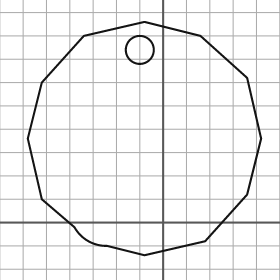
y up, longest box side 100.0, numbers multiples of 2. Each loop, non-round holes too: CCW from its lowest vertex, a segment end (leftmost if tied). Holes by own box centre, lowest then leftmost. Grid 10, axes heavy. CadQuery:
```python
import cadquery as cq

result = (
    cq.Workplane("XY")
    .moveTo(-8.0, -14.0)
    .lineTo(18.0, -8.0)
    .lineTo(36.0, 12.0)
    .lineTo(42.0, 36.0)
    .lineTo(36.0, 62.0)
    .lineTo(16.0, 80.0)
    .lineTo(-8.0, 86.0)
    .lineTo(-34.0, 80.0)
    .lineTo(-52.0, 60.0)
    .lineTo(-58.0, 36.0)
    .lineTo(-52.0, 10.0)
    .lineTo(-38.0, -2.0)
    .threePointArc((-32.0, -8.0), (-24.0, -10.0))
    .close()
    .moveTo(-10.0, 74.0)
    .circle(6.0)
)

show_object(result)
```